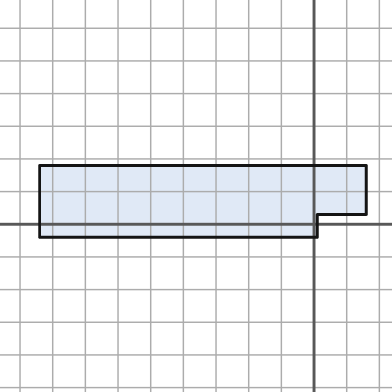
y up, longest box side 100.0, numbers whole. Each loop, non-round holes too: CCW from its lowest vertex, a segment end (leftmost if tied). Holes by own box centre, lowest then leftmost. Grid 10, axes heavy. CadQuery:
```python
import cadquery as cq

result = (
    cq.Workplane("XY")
    .moveTo(-84.0, -4.0)
    .lineTo(1.0, -4.0)
    .lineTo(1.0, 3.0)
    .lineTo(16.0, 3.0)
    .lineTo(16.0, 18.0)
    .lineTo(-84.0, 18.0)
    .close()
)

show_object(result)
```